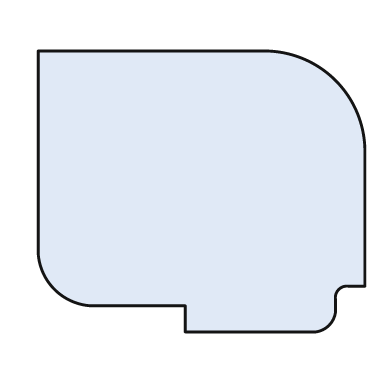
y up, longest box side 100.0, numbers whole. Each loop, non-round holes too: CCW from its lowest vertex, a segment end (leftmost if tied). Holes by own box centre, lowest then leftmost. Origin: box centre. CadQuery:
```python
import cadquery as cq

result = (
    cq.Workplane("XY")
    .moveTo(-5.0, -43.0)
    .lineTo(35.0, -43.0)
    .threePointArc((39.0, -41.0), (41.0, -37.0))
    .lineTo(41.0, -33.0)
    .threePointArc((42.0, -30.0), (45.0, -29.0))
    .lineTo(50.0, -29.0)
    .lineTo(50.0, 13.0)
    .threePointArc((41.0, 34.0), (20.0, 43.0))
    .lineTo(-50.0, 43.0)
    .lineTo(-50.0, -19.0)
    .threePointArc((-45.0, -30.0), (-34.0, -35.0))
    .lineTo(-5.0, -35.0)
    .close()
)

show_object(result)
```